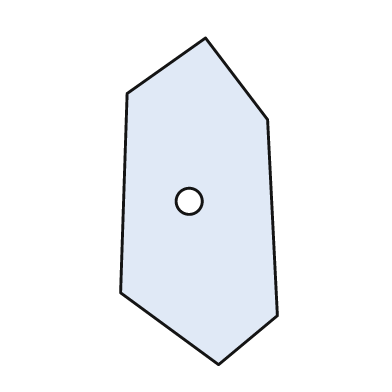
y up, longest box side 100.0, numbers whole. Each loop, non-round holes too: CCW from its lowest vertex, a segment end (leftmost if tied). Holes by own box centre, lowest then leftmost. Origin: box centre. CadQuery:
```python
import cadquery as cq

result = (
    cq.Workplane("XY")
    .moveTo(6.0, -50.0)
    .lineTo(24.0, -35.0)
    .lineTo(21.0, 25.0)
    .lineTo(2.0, 50.0)
    .lineTo(-22.0, 33.0)
    .lineTo(-24.0, -28.0)
    .close()
    .moveTo(-3.0, 0.0)
    .circle(4.0)
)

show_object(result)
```